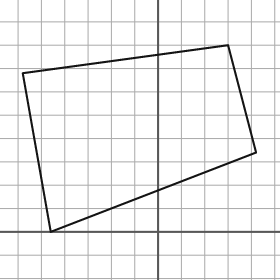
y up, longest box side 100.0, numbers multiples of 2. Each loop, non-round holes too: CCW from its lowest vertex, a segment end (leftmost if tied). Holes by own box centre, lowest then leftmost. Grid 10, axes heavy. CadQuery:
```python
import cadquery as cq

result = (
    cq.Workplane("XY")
    .moveTo(-46.0, 0.0)
    .lineTo(42.0, 34.0)
    .lineTo(30.0, 80.0)
    .lineTo(-58.0, 68.0)
    .close()
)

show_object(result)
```